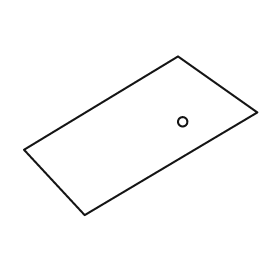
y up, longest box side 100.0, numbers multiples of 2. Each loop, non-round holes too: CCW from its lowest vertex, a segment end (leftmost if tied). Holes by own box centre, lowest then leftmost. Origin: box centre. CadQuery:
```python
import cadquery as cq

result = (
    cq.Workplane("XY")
    .moveTo(-24.0, -34.0)
    .lineTo(50.0, 10.0)
    .lineTo(16.0, 34.0)
    .lineTo(-50.0, -6.0)
    .close()
    .moveTo(18.0, 6.0)
    .circle(2.0)
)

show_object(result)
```